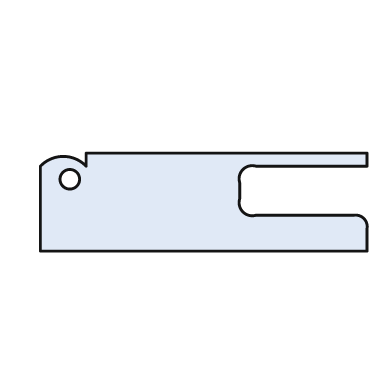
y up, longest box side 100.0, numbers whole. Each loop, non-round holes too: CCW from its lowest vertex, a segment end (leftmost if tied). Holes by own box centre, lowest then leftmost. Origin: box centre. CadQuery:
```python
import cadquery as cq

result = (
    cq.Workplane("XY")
    .moveTo(-50.0, -15.0)
    .lineTo(50.0, -15.0)
    .lineTo(50.0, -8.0)
    .threePointArc((49.0, -5.0), (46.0, -4.0))
    .lineTo(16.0, -4.0)
    .threePointArc((12.0, -3.0), (11.0, 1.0))
    .lineTo(11.0, 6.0)
    .threePointArc((12.0, 10.0), (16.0, 11.0))
    .lineTo(50.0, 11.0)
    .lineTo(50.0, 15.0)
    .lineTo(-36.0, 15.0)
    .lineTo(-36.0, 11.0)
    .threePointArc((-43.0, 14.0), (-50.0, 11.0))
    .close()
    .moveTo(-41.0, 7.0)
    .circle(3.0)
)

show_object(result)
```